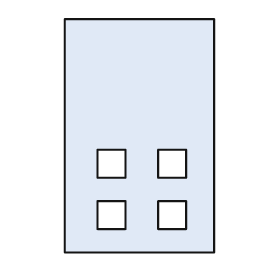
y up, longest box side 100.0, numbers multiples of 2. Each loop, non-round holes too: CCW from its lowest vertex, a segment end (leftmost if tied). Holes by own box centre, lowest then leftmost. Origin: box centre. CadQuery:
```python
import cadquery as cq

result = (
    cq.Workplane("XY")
    .moveTo(-32.0, -50.0)
    .lineTo(32.0, -50.0)
    .lineTo(32.0, 50.0)
    .lineTo(-32.0, 50.0)
    .close()
    .moveTo(-18.0, -40.0)
    .lineTo(-6.0, -40.0)
    .lineTo(-6.0, -28.0)
    .lineTo(-18.0, -28.0)
    .close()
    .moveTo(8.0, -40.0)
    .lineTo(20.0, -40.0)
    .lineTo(20.0, -28.0)
    .lineTo(8.0, -28.0)
    .close()
    .moveTo(-18.0, -18.0)
    .lineTo(-6.0, -18.0)
    .lineTo(-6.0, -6.0)
    .lineTo(-18.0, -6.0)
    .close()
    .moveTo(8.0, -18.0)
    .lineTo(20.0, -18.0)
    .lineTo(20.0, -6.0)
    .lineTo(8.0, -6.0)
    .close()
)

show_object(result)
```